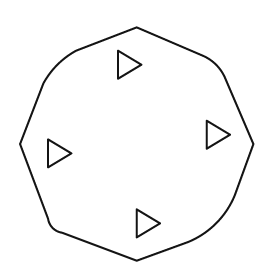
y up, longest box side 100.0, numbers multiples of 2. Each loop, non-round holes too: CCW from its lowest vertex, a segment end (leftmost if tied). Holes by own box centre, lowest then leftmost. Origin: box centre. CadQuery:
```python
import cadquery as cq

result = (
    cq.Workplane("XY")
    .moveTo(0.0, -50.0)
    .lineTo(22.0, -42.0)
    .threePointArc((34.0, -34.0), (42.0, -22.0))
    .lineTo(50.0, 0.0)
    .lineTo(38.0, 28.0)
    .threePointArc((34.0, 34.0), (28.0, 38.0))
    .lineTo(0.0, 50.0)
    .lineTo(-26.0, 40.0)
    .threePointArc((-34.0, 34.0), (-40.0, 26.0))
    .lineTo(-50.0, 0.0)
    .lineTo(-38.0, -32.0)
    .threePointArc((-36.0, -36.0), (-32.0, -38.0))
    .close()
    .moveTo(0.0, -40.0)
    .lineTo(10.0, -34.0)
    .lineTo(0.0, -28.0)
    .close()
    .moveTo(-38.0, -10.0)
    .lineTo(-28.0, -4.0)
    .lineTo(-38.0, 2.0)
    .close()
    .moveTo(30.0, -2.0)
    .lineTo(40.0, 4.0)
    .lineTo(30.0, 10.0)
    .close()
    .moveTo(-8.0, 28.0)
    .lineTo(2.0, 34.0)
    .lineTo(-8.0, 40.0)
    .close()
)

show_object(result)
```